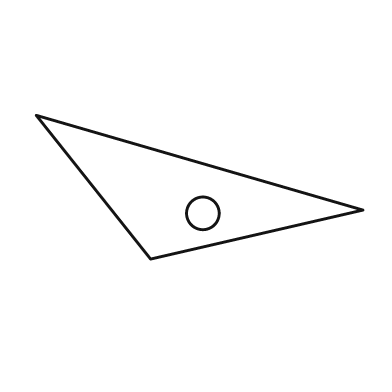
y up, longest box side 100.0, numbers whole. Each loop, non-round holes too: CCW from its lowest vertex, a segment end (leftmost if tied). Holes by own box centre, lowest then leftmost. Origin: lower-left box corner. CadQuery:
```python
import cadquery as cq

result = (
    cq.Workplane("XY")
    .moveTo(35.0, 0.0)
    .lineTo(100.0, 15.0)
    .lineTo(0.0, 44.0)
    .close()
    .moveTo(51.0, 14.0)
    .circle(5.0)
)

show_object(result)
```